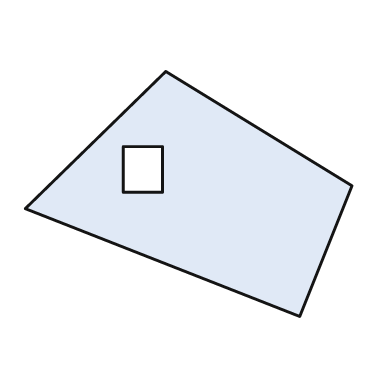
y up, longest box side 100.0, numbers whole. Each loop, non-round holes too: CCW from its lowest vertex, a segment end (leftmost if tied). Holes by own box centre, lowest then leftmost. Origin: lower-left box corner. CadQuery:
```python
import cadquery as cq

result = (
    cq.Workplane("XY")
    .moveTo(84.0, 0.0)
    .lineTo(100.0, 40.0)
    .lineTo(43.0, 75.0)
    .lineTo(0.0, 33.0)
    .close()
    .moveTo(30.0, 38.0)
    .lineTo(42.0, 38.0)
    .lineTo(42.0, 52.0)
    .lineTo(30.0, 52.0)
    .close()
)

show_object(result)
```